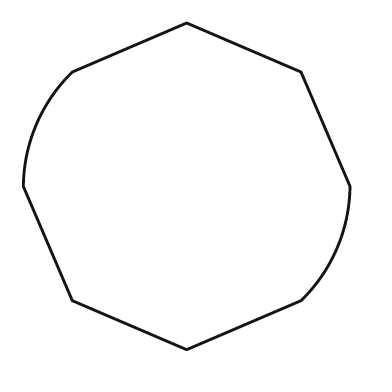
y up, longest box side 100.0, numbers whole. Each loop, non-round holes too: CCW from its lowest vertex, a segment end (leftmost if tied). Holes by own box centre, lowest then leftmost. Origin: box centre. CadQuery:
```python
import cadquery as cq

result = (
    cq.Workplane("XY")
    .moveTo(0.0, -50.0)
    .lineTo(35.0, -35.0)
    .threePointArc((46.0, -19.0), (50.0, 0.0))
    .lineTo(35.0, 35.0)
    .lineTo(0.0, 50.0)
    .lineTo(-35.0, 35.0)
    .threePointArc((-46.0, 19.0), (-50.0, 0.0))
    .lineTo(-35.0, -35.0)
    .close()
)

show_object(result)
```